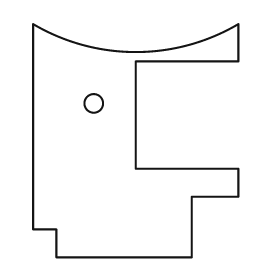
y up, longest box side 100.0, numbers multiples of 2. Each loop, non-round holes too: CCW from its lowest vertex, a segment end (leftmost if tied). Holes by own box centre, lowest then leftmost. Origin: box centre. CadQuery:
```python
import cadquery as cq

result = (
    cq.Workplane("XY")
    .moveTo(-34.0, -50.0)
    .lineTo(24.0, -50.0)
    .lineTo(24.0, -24.0)
    .lineTo(44.0, -24.0)
    .lineTo(44.0, -12.0)
    .lineTo(0.0, -12.0)
    .lineTo(0.0, 34.0)
    .lineTo(44.0, 34.0)
    .lineTo(44.0, 50.0)
    .threePointArc((0.0, 38.0), (-44.0, 50.0))
    .lineTo(-44.0, -38.0)
    .lineTo(-34.0, -38.0)
    .close()
    .moveTo(-18.0, 16.0)
    .circle(4.0)
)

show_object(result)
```